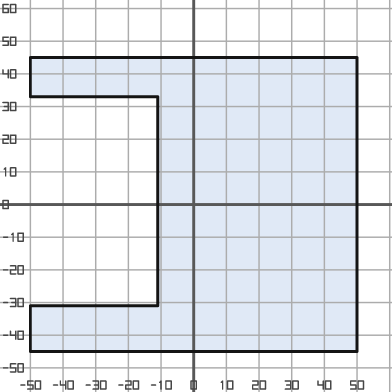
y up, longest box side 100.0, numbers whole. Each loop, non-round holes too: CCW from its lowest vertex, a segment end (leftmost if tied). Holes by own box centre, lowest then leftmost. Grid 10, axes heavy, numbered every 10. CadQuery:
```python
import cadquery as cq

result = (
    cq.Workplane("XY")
    .moveTo(-50.0, -45.0)
    .lineTo(50.0, -45.0)
    .lineTo(50.0, 45.0)
    .lineTo(-50.0, 45.0)
    .lineTo(-50.0, 33.0)
    .lineTo(-11.0, 33.0)
    .lineTo(-11.0, -31.0)
    .lineTo(-50.0, -31.0)
    .close()
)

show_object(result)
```